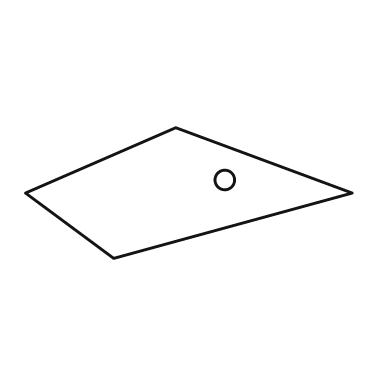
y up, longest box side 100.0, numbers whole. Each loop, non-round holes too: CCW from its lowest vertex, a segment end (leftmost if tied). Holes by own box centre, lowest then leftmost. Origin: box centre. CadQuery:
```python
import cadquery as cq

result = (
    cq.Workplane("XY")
    .moveTo(-23.0, -20.0)
    .lineTo(50.0, 0.0)
    .lineTo(-4.0, 20.0)
    .lineTo(-50.0, 0.0)
    .close()
    .moveTo(11.0, 4.0)
    .circle(3.0)
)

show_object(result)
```